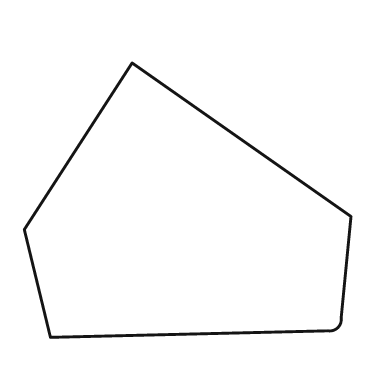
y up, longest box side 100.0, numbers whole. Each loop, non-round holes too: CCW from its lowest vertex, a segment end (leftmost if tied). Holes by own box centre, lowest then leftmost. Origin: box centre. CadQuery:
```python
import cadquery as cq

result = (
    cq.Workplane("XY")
    .moveTo(-42.0, -42.0)
    .lineTo(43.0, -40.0)
    .threePointArc((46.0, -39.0), (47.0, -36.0))
    .lineTo(50.0, -5.0)
    .lineTo(-17.0, 42.0)
    .lineTo(-50.0, -9.0)
    .close()
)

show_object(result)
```